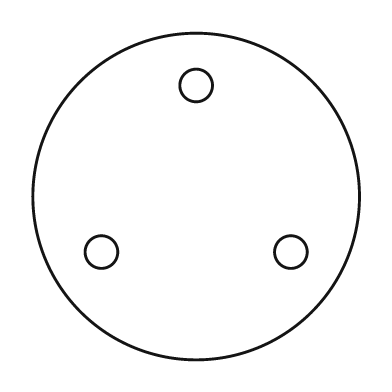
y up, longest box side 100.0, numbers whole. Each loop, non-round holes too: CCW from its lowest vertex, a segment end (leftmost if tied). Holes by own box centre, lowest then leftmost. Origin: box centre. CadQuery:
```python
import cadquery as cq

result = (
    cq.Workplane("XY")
    .moveTo(0.0, 0.0)
    .circle(50.0)
    .moveTo(-29.0, -17.0)
    .circle(5.0)
    .moveTo(29.0, -17.0)
    .circle(5.0)
    .moveTo(0.0, 34.0)
    .circle(5.0)
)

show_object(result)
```